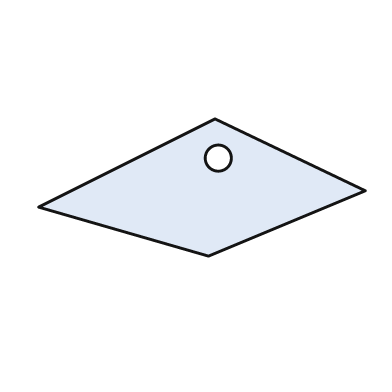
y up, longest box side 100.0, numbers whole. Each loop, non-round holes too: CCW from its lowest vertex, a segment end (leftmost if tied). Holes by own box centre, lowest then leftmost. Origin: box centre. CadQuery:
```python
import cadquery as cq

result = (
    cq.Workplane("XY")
    .moveTo(2.0, -21.0)
    .lineTo(50.0, -1.0)
    .lineTo(4.0, 21.0)
    .lineTo(-50.0, -6.0)
    .close()
    .moveTo(5.0, 9.0)
    .circle(4.0)
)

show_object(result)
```